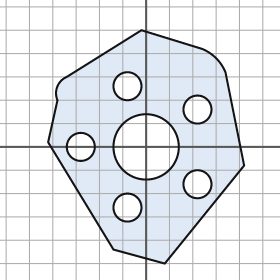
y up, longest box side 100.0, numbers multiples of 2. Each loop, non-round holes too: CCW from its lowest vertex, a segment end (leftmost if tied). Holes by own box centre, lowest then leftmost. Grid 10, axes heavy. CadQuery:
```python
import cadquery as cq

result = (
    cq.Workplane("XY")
    .moveTo(8.0, -50.0)
    .lineTo(42.0, -8.0)
    .lineTo(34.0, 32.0)
    .threePointArc((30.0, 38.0), (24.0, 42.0))
    .lineTo(-2.0, 50.0)
    .lineTo(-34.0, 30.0)
    .threePointArc((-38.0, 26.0), (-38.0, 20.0))
    .lineTo(-42.0, 2.0)
    .lineTo(-14.0, -44.0)
    .close()
    .moveTo(-8.0, -26.0)
    .circle(6.0)
    .moveTo(22.0, -16.0)
    .circle(6.0)
    .moveTo(-28.0, 0.0)
    .circle(6.0)
    .moveTo(0.0, 0.0)
    .circle(14.0)
    .moveTo(22.0, 16.0)
    .circle(6.0)
    .moveTo(-8.0, 26.0)
    .circle(6.0)
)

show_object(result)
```